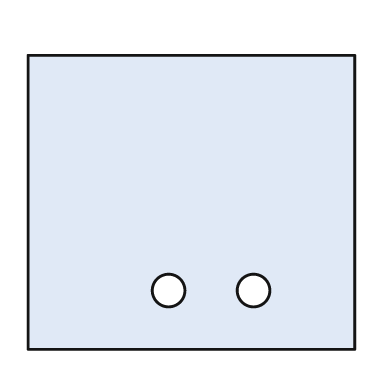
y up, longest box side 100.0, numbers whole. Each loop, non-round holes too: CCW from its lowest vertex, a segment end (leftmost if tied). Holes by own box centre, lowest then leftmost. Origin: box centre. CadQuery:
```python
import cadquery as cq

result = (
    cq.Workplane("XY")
    .moveTo(-50.0, -45.0)
    .lineTo(50.0, -45.0)
    .lineTo(50.0, 45.0)
    .lineTo(-50.0, 45.0)
    .close()
    .moveTo(-7.0, -27.0)
    .circle(5.0)
    .moveTo(19.0, -27.0)
    .circle(5.0)
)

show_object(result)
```